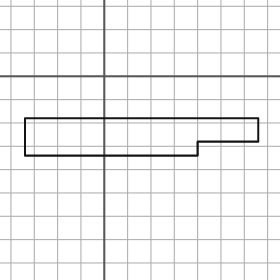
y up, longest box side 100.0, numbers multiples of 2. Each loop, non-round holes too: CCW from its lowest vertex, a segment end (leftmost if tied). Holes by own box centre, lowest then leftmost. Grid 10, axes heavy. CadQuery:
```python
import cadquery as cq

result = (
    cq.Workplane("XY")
    .moveTo(-34.0, -34.0)
    .lineTo(40.0, -34.0)
    .lineTo(40.0, -28.0)
    .lineTo(66.0, -28.0)
    .lineTo(66.0, -18.0)
    .lineTo(-34.0, -18.0)
    .close()
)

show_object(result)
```